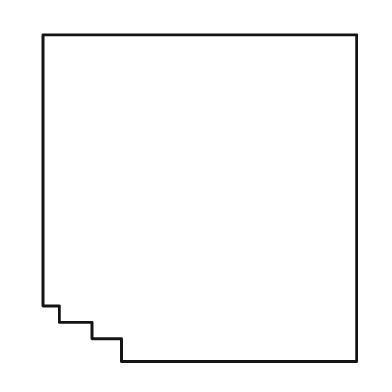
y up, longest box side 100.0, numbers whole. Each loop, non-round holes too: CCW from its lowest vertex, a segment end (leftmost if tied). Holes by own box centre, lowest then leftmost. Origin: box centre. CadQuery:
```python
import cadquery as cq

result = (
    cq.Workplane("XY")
    .moveTo(-24.0, -50.0)
    .lineTo(48.0, -50.0)
    .lineTo(48.0, 50.0)
    .lineTo(-48.0, 50.0)
    .lineTo(-48.0, -33.0)
    .lineTo(-43.0, -33.0)
    .lineTo(-43.0, -38.0)
    .lineTo(-33.0, -38.0)
    .lineTo(-33.0, -43.0)
    .lineTo(-24.0, -43.0)
    .close()
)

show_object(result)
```